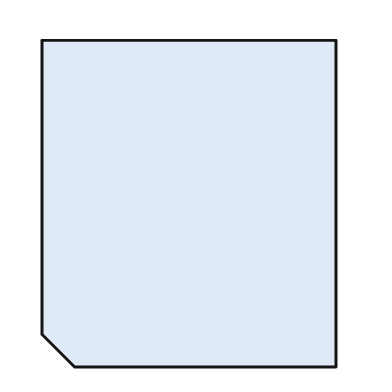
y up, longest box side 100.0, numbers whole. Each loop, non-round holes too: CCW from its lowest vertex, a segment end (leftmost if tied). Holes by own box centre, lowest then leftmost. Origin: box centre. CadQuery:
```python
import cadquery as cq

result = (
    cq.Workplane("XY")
    .moveTo(-35.0, -50.0)
    .lineTo(45.0, -50.0)
    .lineTo(45.0, 50.0)
    .lineTo(-45.0, 50.0)
    .lineTo(-45.0, -40.0)
    .close()
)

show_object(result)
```